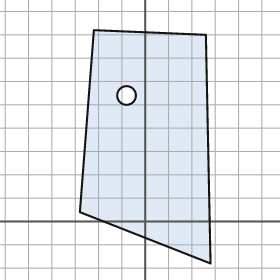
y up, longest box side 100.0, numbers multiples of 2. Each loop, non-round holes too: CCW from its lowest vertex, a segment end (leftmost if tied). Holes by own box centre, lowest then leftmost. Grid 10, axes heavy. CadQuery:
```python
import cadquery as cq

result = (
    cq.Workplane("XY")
    .moveTo(28.0, -18.0)
    .lineTo(26.0, 80.0)
    .lineTo(-22.0, 82.0)
    .lineTo(-28.0, 4.0)
    .close()
    .moveTo(-8.0, 54.0)
    .circle(4.0)
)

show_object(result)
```